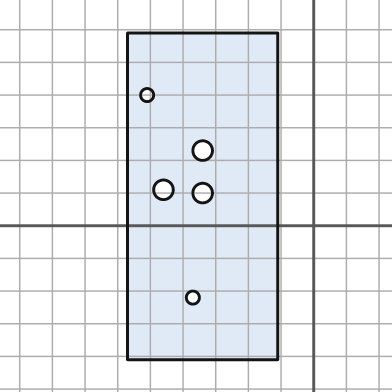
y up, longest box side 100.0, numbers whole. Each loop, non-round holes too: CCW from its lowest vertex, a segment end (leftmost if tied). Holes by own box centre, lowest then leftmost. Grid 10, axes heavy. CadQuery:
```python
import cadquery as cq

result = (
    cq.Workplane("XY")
    .moveTo(-57.0, -41.0)
    .lineTo(-11.0, -41.0)
    .lineTo(-11.0, 59.0)
    .lineTo(-57.0, 59.0)
    .close()
    .moveTo(-37.0, -22.0)
    .circle(2.0)
    .moveTo(-34.0, 10.0)
    .circle(3.0)
    .moveTo(-46.0, 11.0)
    .circle(3.0)
    .moveTo(-34.0, 23.0)
    .circle(3.0)
    .moveTo(-51.0, 40.0)
    .circle(2.0)
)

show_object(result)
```